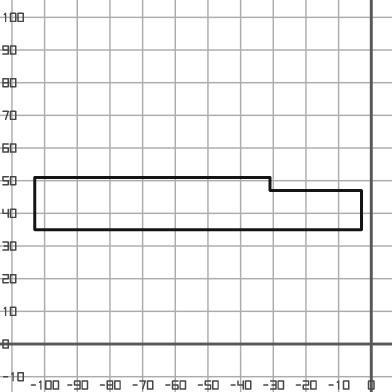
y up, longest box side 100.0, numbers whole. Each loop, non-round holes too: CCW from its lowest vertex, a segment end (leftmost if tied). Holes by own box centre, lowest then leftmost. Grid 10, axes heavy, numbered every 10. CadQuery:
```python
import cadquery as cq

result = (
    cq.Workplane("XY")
    .moveTo(-103.0, 35.0)
    .lineTo(-3.0, 35.0)
    .lineTo(-3.0, 47.0)
    .lineTo(-31.0, 47.0)
    .lineTo(-31.0, 51.0)
    .lineTo(-103.0, 51.0)
    .close()
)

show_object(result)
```